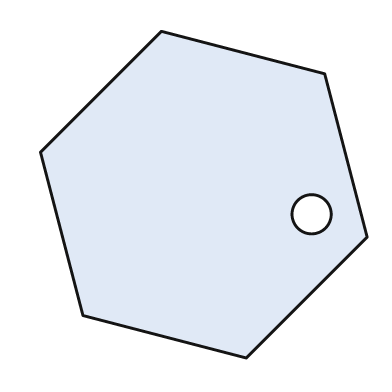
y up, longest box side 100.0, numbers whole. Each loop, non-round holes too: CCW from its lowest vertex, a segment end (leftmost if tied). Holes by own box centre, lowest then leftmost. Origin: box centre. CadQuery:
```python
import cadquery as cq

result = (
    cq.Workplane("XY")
    .moveTo(13.0, -50.0)
    .lineTo(50.0, -13.0)
    .lineTo(37.0, 37.0)
    .lineTo(-13.0, 50.0)
    .lineTo(-50.0, 13.0)
    .lineTo(-37.0, -37.0)
    .close()
    .moveTo(33.0, -6.0)
    .circle(6.0)
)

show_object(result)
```